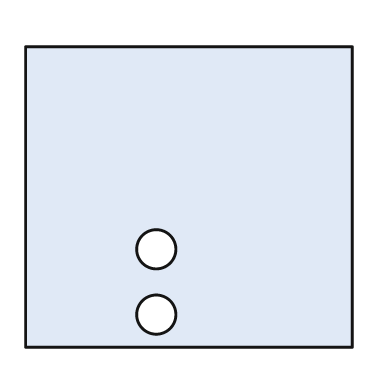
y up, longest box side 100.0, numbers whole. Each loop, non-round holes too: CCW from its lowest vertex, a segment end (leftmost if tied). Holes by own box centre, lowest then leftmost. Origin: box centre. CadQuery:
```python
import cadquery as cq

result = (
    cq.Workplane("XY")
    .moveTo(-50.0, -46.0)
    .lineTo(50.0, -46.0)
    .lineTo(50.0, 46.0)
    .lineTo(-50.0, 46.0)
    .close()
    .moveTo(-10.0, -36.0)
    .circle(6.0)
    .moveTo(-10.0, -16.0)
    .circle(6.0)
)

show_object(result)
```